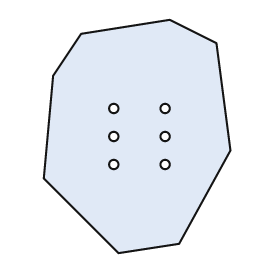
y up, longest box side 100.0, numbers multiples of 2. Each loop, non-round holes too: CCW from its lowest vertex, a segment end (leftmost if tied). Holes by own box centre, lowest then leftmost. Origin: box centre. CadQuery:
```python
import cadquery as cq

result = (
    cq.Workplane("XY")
    .moveTo(-8.0, -50.0)
    .lineTo(18.0, -46.0)
    .lineTo(40.0, -6.0)
    .lineTo(34.0, 40.0)
    .lineTo(14.0, 50.0)
    .lineTo(-24.0, 44.0)
    .lineTo(-36.0, 26.0)
    .lineTo(-40.0, -18.0)
    .close()
    .moveTo(-10.0, -12.0)
    .circle(2.0)
    .moveTo(12.0, -12.0)
    .circle(2.0)
    .moveTo(-10.0, 0.0)
    .circle(2.0)
    .moveTo(12.0, 0.0)
    .circle(2.0)
    .moveTo(-10.0, 12.0)
    .circle(2.0)
    .moveTo(12.0, 12.0)
    .circle(2.0)
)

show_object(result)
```